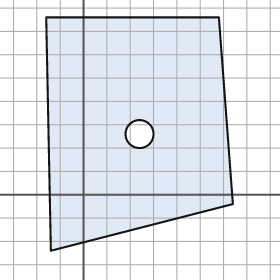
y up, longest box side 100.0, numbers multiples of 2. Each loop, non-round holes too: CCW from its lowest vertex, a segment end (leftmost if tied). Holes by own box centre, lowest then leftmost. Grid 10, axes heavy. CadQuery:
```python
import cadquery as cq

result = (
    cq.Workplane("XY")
    .moveTo(-14.0, -24.0)
    .lineTo(64.0, -4.0)
    .lineTo(58.0, 76.0)
    .lineTo(-16.0, 76.0)
    .close()
    .moveTo(24.0, 26.0)
    .circle(6.0)
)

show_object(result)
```